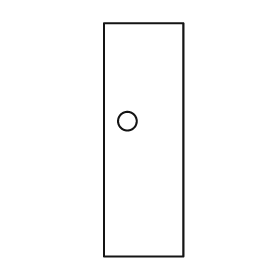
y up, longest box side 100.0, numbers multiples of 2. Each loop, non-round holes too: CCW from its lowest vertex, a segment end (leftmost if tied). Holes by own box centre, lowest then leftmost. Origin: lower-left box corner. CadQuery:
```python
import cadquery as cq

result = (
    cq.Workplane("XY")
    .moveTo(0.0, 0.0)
    .lineTo(34.0, 0.0)
    .lineTo(34.0, 100.0)
    .lineTo(0.0, 100.0)
    .close()
    .moveTo(10.0, 58.0)
    .circle(4.0)
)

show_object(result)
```